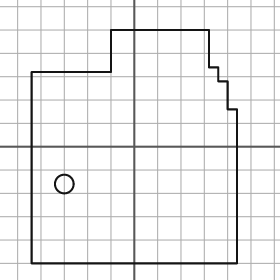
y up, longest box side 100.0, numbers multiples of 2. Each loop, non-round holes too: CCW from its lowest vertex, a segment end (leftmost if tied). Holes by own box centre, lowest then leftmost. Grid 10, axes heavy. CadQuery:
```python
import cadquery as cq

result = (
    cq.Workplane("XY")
    .moveTo(-44.0, -50.0)
    .lineTo(44.0, -50.0)
    .lineTo(44.0, 16.0)
    .lineTo(40.0, 16.0)
    .lineTo(40.0, 28.0)
    .lineTo(36.0, 28.0)
    .lineTo(36.0, 34.0)
    .lineTo(32.0, 34.0)
    .lineTo(32.0, 50.0)
    .lineTo(-10.0, 50.0)
    .lineTo(-10.0, 32.0)
    .lineTo(-44.0, 32.0)
    .close()
    .moveTo(-30.0, -16.0)
    .circle(4.0)
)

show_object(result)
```